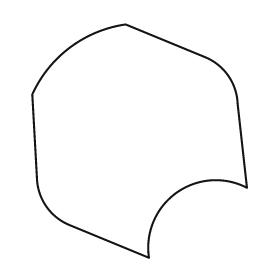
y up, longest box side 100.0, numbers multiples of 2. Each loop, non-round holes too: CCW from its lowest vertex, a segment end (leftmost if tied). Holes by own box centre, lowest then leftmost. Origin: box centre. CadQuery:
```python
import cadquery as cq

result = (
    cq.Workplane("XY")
    .moveTo(4.0, -50.0)
    .threePointArc((16.0, -22.0), (46.0, -20.0))
    .lineTo(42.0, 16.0)
    .threePointArc((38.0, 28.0), (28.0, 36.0))
    .lineTo(-6.0, 50.0)
    .threePointArc((-30.0, 40.0), (-46.0, 20.0))
    .lineTo(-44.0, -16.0)
    .threePointArc((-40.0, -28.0), (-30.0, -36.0))
    .close()
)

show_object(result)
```